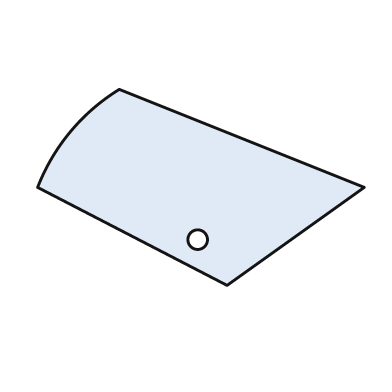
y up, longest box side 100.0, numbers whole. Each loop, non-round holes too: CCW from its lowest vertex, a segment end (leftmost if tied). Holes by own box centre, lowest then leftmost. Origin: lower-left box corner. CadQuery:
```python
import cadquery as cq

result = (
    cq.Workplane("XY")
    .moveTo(58.0, 0.0)
    .lineTo(100.0, 30.0)
    .lineTo(25.0, 60.0)
    .threePointArc((10.0, 47.0), (0.0, 30.0))
    .close()
    .moveTo(49.0, 14.0)
    .circle(3.0)
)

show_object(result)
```